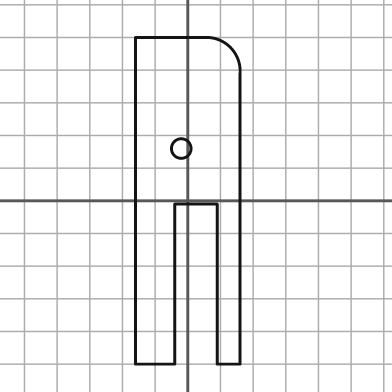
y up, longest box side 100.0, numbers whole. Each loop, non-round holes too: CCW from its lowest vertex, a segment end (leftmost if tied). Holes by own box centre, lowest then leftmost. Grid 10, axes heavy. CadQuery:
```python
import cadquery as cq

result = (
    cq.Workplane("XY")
    .moveTo(-16.0, -50.0)
    .lineTo(-4.0, -50.0)
    .lineTo(-4.0, -1.0)
    .lineTo(9.0, -1.0)
    .lineTo(9.0, -50.0)
    .lineTo(16.0, -50.0)
    .lineTo(16.0, 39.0)
    .threePointArc((13.0, 47.0), (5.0, 50.0))
    .lineTo(-16.0, 50.0)
    .close()
    .moveTo(-2.0, 16.0)
    .circle(3.0)
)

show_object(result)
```